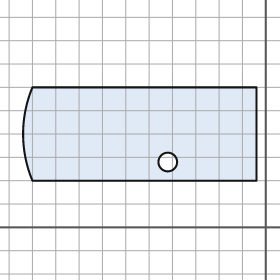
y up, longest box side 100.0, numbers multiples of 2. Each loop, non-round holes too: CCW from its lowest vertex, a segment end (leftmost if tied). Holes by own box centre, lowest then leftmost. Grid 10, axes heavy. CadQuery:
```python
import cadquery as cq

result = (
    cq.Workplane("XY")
    .moveTo(-100.0, 20.0)
    .lineTo(-4.0, 20.0)
    .lineTo(-4.0, 60.0)
    .lineTo(-100.0, 60.0)
    .threePointArc((-104.0, 40.0), (-100.0, 20.0))
    .close()
    .moveTo(-42.0, 28.0)
    .circle(4.0)
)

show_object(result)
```